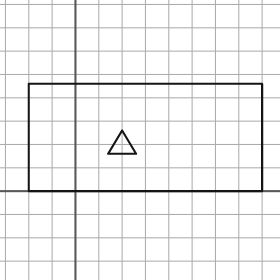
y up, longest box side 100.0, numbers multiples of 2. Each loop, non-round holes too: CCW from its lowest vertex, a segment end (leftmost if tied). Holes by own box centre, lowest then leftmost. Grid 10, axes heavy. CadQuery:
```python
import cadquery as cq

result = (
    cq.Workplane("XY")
    .moveTo(-20.0, 0.0)
    .lineTo(80.0, 0.0)
    .lineTo(80.0, 46.0)
    .lineTo(-20.0, 46.0)
    .close()
    .moveTo(14.0, 16.0)
    .lineTo(26.0, 16.0)
    .lineTo(20.0, 26.0)
    .close()
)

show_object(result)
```